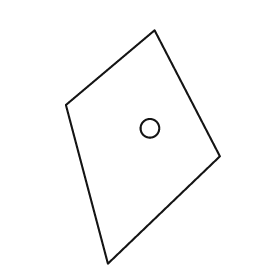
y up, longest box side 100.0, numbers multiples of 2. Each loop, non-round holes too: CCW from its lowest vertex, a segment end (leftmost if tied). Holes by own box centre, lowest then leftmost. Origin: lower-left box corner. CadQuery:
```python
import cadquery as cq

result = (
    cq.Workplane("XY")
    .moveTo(18.0, 0.0)
    .lineTo(66.0, 46.0)
    .lineTo(38.0, 100.0)
    .lineTo(0.0, 68.0)
    .close()
    .moveTo(36.0, 58.0)
    .circle(4.0)
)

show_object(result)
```